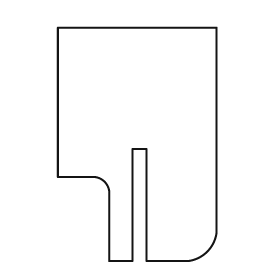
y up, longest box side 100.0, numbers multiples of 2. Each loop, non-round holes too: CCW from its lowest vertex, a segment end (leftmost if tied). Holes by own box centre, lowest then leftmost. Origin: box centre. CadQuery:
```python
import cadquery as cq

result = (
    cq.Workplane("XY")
    .moveTo(-12.0, -50.0)
    .lineTo(-2.0, -50.0)
    .lineTo(-2.0, -2.0)
    .lineTo(4.0, -2.0)
    .lineTo(4.0, -50.0)
    .lineTo(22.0, -50.0)
    .threePointArc((30.0, -46.0), (34.0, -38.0))
    .lineTo(34.0, 50.0)
    .lineTo(-34.0, 50.0)
    .lineTo(-34.0, -14.0)
    .lineTo(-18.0, -14.0)
    .threePointArc((-14.0, -16.0), (-12.0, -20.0))
    .close()
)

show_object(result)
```